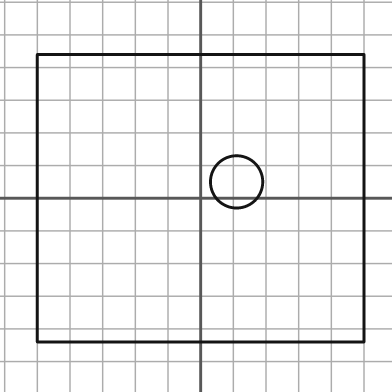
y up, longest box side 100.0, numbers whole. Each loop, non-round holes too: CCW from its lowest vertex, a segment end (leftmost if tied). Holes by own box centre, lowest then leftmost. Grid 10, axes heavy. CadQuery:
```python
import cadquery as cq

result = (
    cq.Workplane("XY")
    .moveTo(-50.0, -44.0)
    .lineTo(50.0, -44.0)
    .lineTo(50.0, 44.0)
    .lineTo(-50.0, 44.0)
    .close()
    .moveTo(11.0, 5.0)
    .circle(8.0)
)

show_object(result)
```